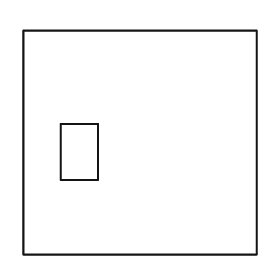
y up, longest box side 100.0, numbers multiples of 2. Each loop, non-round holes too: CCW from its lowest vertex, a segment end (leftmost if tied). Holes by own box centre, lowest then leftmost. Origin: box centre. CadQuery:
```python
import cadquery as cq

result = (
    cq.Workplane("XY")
    .moveTo(-50.0, -48.0)
    .lineTo(50.0, -48.0)
    .lineTo(50.0, 48.0)
    .lineTo(-50.0, 48.0)
    .close()
    .moveTo(-34.0, -16.0)
    .lineTo(-18.0, -16.0)
    .lineTo(-18.0, 8.0)
    .lineTo(-34.0, 8.0)
    .close()
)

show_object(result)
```